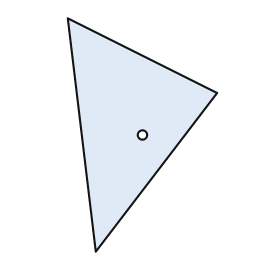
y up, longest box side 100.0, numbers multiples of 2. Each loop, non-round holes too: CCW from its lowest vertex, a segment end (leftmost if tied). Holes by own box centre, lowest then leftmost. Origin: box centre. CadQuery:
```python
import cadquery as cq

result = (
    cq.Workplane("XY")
    .moveTo(-20.0, -50.0)
    .lineTo(32.0, 18.0)
    .lineTo(-32.0, 50.0)
    .close()
    .moveTo(0.0, 0.0)
    .circle(2.0)
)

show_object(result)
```